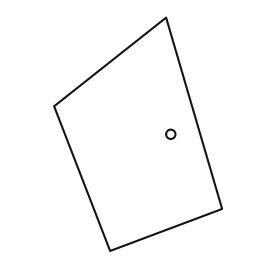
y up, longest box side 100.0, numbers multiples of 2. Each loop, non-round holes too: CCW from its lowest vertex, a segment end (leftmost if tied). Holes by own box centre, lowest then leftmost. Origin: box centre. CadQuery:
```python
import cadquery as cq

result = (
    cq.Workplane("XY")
    .moveTo(-12.0, -50.0)
    .lineTo(36.0, -32.0)
    .lineTo(12.0, 50.0)
    .lineTo(-36.0, 12.0)
    .close()
    .moveTo(14.0, 0.0)
    .circle(2.0)
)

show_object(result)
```